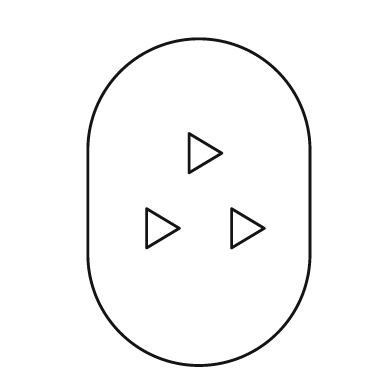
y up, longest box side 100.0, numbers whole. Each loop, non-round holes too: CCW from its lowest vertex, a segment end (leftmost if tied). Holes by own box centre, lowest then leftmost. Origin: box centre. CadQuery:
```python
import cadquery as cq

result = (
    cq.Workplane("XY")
    .moveTo(-34.0, -16.0)
    .threePointArc((0.0, -50.0), (34.0, -16.0))
    .lineTo(34.0, 16.0)
    .threePointArc((0.0, 50.0), (-34.0, 16.0))
    .close()
    .moveTo(-16.0, -14.0)
    .lineTo(-6.0, -8.0)
    .lineTo(-16.0, -2.0)
    .close()
    .moveTo(10.0, -14.0)
    .lineTo(20.0, -8.0)
    .lineTo(10.0, -2.0)
    .close()
    .moveTo(-3.0, 9.0)
    .lineTo(7.0, 15.0)
    .lineTo(-3.0, 21.0)
    .close()
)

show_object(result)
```